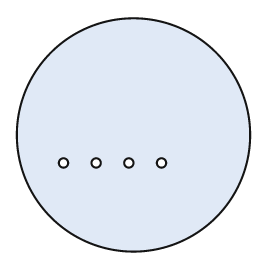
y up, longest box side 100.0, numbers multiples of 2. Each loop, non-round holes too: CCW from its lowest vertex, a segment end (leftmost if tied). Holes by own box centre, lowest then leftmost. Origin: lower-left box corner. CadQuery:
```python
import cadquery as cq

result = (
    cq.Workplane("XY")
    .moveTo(50.0, 50.0)
    .circle(50.0)
    .moveTo(20.0, 38.0)
    .circle(2.0)
    .moveTo(34.0, 38.0)
    .circle(2.0)
    .moveTo(48.0, 38.0)
    .circle(2.0)
    .moveTo(62.0, 38.0)
    .circle(2.0)
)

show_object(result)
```